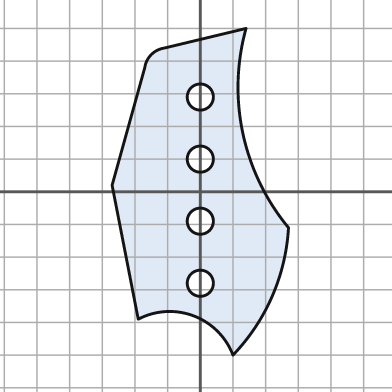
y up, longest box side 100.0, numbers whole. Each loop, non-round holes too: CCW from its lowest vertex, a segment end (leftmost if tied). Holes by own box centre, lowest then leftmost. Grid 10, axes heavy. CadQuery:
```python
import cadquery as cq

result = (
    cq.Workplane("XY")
    .moveTo(10.0, -50.0)
    .threePointArc((22.0, -32.0), (27.0, -11.0))
    .threePointArc((13.0, 18.0), (14.0, 50.0))
    .lineTo(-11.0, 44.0)
    .threePointArc((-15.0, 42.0), (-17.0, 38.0))
    .lineTo(-27.0, 2.0)
    .lineTo(-19.0, -39.0)
    .threePointArc((-2.0, -38.0), (10.0, -50.0))
    .close()
    .moveTo(0.0, -28.0)
    .circle(4.0)
    .moveTo(0.0, -9.0)
    .circle(4.0)
    .moveTo(0.0, 10.0)
    .circle(4.0)
    .moveTo(0.0, 29.0)
    .circle(4.0)
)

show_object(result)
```